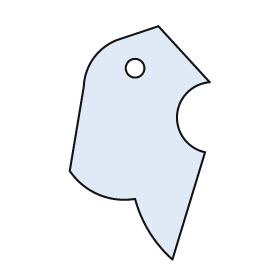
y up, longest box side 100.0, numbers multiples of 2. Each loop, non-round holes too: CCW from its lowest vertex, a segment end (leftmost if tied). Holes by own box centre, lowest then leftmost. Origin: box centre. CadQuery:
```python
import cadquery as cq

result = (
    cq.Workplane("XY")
    .moveTo(14.0, -50.0)
    .lineTo(28.0, -4.0)
    .threePointArc((16.0, 12.0), (30.0, 26.0))
    .lineTo(8.0, 50.0)
    .lineTo(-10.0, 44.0)
    .threePointArc((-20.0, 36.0), (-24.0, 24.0))
    .lineTo(-30.0, -12.0)
    .threePointArc((-18.0, -22.0), (-2.0, -24.0))
    .threePointArc((4.0, -38.0), (14.0, -50.0))
    .close()
    .moveTo(-2.0, 32.0)
    .circle(4.0)
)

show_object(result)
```